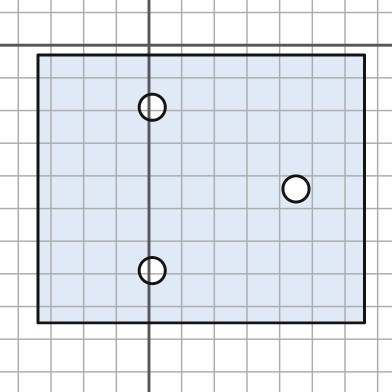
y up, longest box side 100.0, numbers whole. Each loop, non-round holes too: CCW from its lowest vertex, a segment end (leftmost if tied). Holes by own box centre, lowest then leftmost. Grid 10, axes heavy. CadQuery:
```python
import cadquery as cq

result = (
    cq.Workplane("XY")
    .moveTo(-34.0, -85.0)
    .lineTo(66.0, -85.0)
    .lineTo(66.0, -3.0)
    .lineTo(-34.0, -3.0)
    .close()
    .moveTo(1.0, -69.0)
    .circle(4.0)
    .moveTo(45.0, -44.0)
    .circle(4.0)
    .moveTo(1.0, -19.0)
    .circle(4.0)
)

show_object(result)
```